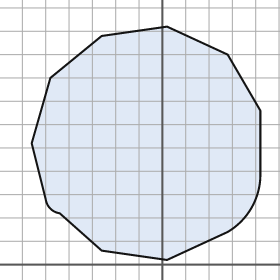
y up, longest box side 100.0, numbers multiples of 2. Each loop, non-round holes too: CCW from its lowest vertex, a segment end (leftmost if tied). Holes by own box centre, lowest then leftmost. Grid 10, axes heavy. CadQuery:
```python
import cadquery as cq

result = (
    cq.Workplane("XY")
    .moveTo(2.0, 2.0)
    .lineTo(28.0, 14.0)
    .threePointArc((38.0, 24.0), (42.0, 38.0))
    .lineTo(42.0, 66.0)
    .lineTo(28.0, 90.0)
    .lineTo(2.0, 102.0)
    .lineTo(-26.0, 98.0)
    .lineTo(-48.0, 80.0)
    .lineTo(-56.0, 52.0)
    .lineTo(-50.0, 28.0)
    .threePointArc((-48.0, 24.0), (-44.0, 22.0))
    .lineTo(-26.0, 6.0)
    .close()
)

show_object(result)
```